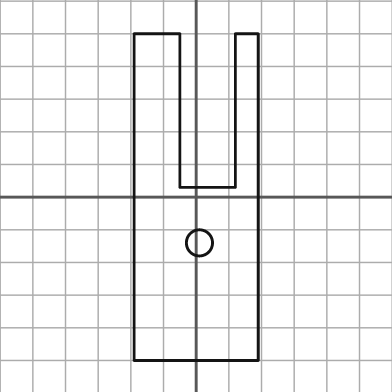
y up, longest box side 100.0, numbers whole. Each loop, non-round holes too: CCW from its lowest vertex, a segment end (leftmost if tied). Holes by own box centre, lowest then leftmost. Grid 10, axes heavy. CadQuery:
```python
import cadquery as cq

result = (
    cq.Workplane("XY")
    .moveTo(-19.0, -50.0)
    .lineTo(19.0, -50.0)
    .lineTo(19.0, 50.0)
    .lineTo(12.0, 50.0)
    .lineTo(12.0, 3.0)
    .lineTo(-5.0, 3.0)
    .lineTo(-5.0, 50.0)
    .lineTo(-19.0, 50.0)
    .close()
    .moveTo(1.0, -14.0)
    .circle(4.0)
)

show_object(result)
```